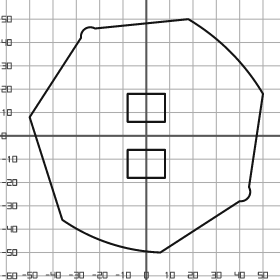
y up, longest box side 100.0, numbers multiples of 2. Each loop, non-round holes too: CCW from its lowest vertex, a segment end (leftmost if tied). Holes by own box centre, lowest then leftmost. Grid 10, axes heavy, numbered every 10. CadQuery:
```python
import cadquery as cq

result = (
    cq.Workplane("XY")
    .moveTo(6.0, -50.0)
    .lineTo(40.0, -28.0)
    .threePointArc((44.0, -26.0), (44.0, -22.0))
    .lineTo(50.0, 18.0)
    .threePointArc((36.0, 36.0), (18.0, 50.0))
    .lineTo(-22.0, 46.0)
    .threePointArc((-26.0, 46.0), (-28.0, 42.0))
    .lineTo(-50.0, 8.0)
    .lineTo(-36.0, -36.0)
    .threePointArc((-16.0, -46.0), (6.0, -50.0))
    .close()
    .moveTo(-8.0, -18.0)
    .lineTo(8.0, -18.0)
    .lineTo(8.0, -6.0)
    .lineTo(-8.0, -6.0)
    .close()
    .moveTo(-8.0, 6.0)
    .lineTo(8.0, 6.0)
    .lineTo(8.0, 18.0)
    .lineTo(-8.0, 18.0)
    .close()
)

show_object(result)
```